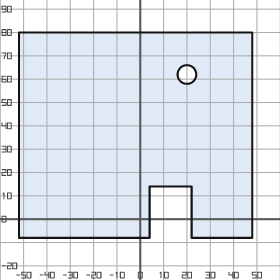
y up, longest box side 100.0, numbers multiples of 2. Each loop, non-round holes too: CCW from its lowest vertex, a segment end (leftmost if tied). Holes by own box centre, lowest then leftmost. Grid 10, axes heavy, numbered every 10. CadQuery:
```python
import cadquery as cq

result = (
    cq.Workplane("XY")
    .moveTo(-52.0, -8.0)
    .lineTo(4.0, -8.0)
    .lineTo(4.0, 14.0)
    .lineTo(22.0, 14.0)
    .lineTo(22.0, -8.0)
    .lineTo(48.0, -8.0)
    .lineTo(48.0, 80.0)
    .lineTo(-52.0, 80.0)
    .close()
    .moveTo(20.0, 62.0)
    .circle(4.0)
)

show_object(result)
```